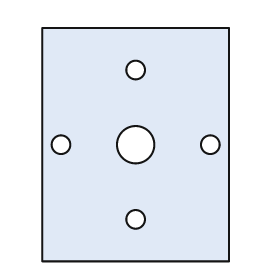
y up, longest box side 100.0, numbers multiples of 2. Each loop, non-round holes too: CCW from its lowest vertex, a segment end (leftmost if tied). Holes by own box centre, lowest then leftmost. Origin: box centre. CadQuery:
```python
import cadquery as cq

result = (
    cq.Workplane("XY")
    .moveTo(-40.0, -50.0)
    .lineTo(40.0, -50.0)
    .lineTo(40.0, 50.0)
    .lineTo(-40.0, 50.0)
    .close()
    .moveTo(0.0, -32.0)
    .circle(4.0)
    .moveTo(-32.0, 0.0)
    .circle(4.0)
    .moveTo(0.0, 0.0)
    .circle(8.0)
    .moveTo(32.0, 0.0)
    .circle(4.0)
    .moveTo(0.0, 32.0)
    .circle(4.0)
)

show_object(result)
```